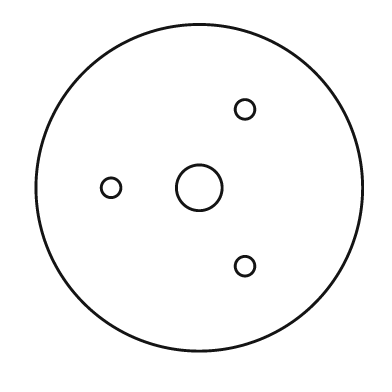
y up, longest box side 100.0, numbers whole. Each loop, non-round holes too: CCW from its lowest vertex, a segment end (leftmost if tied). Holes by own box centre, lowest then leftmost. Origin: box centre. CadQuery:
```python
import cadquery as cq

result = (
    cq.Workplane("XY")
    .moveTo(0.0, 0.0)
    .circle(50.0)
    .moveTo(14.0, -24.0)
    .circle(3.0)
    .moveTo(-27.0, 0.0)
    .circle(3.0)
    .moveTo(0.0, 0.0)
    .circle(7.0)
    .moveTo(14.0, 24.0)
    .circle(3.0)
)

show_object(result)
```